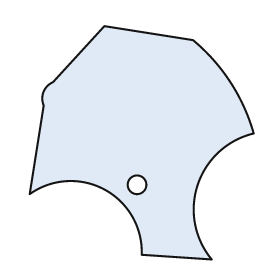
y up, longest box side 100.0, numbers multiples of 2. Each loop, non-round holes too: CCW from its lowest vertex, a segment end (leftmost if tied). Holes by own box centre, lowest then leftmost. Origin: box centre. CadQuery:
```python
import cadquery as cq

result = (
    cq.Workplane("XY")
    .moveTo(30.0, -50.0)
    .threePointArc((24.0, -18.0), (48.0, 4.0))
    .threePointArc((38.0, 26.0), (22.0, 44.0))
    .lineTo(-16.0, 50.0)
    .lineTo(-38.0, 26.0)
    .threePointArc((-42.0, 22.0), (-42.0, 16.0))
    .lineTo(-48.0, -22.0)
    .threePointArc((-16.0, -20.0), (0.0, -48.0))
    .close()
    .moveTo(-2.0, -18.0)
    .circle(4.0)
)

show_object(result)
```